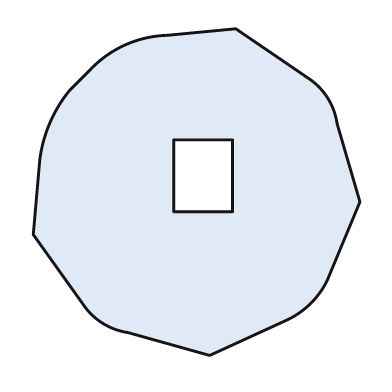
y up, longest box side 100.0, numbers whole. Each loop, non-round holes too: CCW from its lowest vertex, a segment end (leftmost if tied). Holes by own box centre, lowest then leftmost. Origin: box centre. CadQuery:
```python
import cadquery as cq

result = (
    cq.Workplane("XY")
    .moveTo(4.0, -50.0)
    .lineTo(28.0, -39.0)
    .threePointArc((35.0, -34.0), (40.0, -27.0))
    .lineTo(50.0, -3.0)
    .lineTo(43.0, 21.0)
    .threePointArc((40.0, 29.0), (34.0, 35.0))
    .lineTo(12.0, 50.0)
    .lineTo(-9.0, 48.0)
    .threePointArc((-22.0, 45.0), (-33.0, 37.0))
    .lineTo(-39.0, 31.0)
    .threePointArc((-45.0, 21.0), (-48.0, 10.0))
    .lineTo(-50.0, -13.0)
    .lineTo(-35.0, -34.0)
    .threePointArc((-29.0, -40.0), (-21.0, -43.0))
    .close()
    .moveTo(-7.0, -6.0)
    .lineTo(11.0, -6.0)
    .lineTo(11.0, 16.0)
    .lineTo(-7.0, 16.0)
    .close()
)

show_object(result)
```